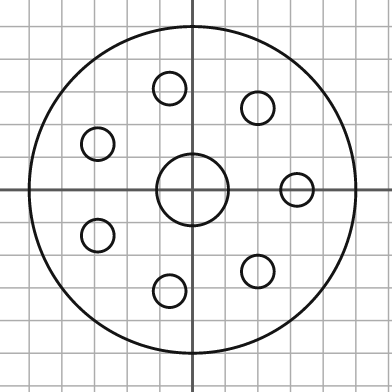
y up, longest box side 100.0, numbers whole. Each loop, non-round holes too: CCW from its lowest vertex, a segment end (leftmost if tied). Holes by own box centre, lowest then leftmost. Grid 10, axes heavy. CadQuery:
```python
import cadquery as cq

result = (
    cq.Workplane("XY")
    .moveTo(0.0, 0.0)
    .circle(50.0)
    .moveTo(-7.0, -31.0)
    .circle(5.0)
    .moveTo(20.0, -25.0)
    .circle(5.0)
    .moveTo(-29.0, -14.0)
    .circle(5.0)
    .moveTo(0.0, 0.0)
    .circle(11.0)
    .moveTo(32.0, 0.0)
    .circle(5.0)
    .moveTo(-29.0, 14.0)
    .circle(5.0)
    .moveTo(20.0, 25.0)
    .circle(5.0)
    .moveTo(-7.0, 31.0)
    .circle(5.0)
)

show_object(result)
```